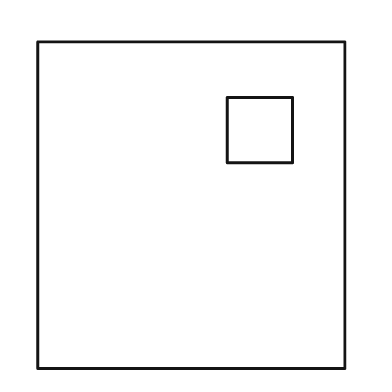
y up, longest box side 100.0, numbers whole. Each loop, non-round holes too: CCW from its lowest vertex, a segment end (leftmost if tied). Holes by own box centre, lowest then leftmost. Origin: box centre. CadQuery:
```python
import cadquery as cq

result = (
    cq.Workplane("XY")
    .moveTo(-47.0, -50.0)
    .lineTo(47.0, -50.0)
    .lineTo(47.0, 50.0)
    .lineTo(-47.0, 50.0)
    .close()
    .moveTo(11.0, 13.0)
    .lineTo(31.0, 13.0)
    .lineTo(31.0, 33.0)
    .lineTo(11.0, 33.0)
    .close()
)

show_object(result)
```